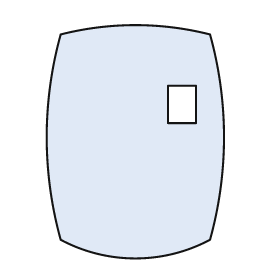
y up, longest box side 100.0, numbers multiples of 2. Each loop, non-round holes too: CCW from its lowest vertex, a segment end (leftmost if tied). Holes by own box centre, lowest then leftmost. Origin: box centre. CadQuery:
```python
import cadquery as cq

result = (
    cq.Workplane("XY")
    .moveTo(-32.0, -42.0)
    .threePointArc((0.0, -50.0), (32.0, -42.0))
    .threePointArc((38.0, 2.0), (32.0, 46.0))
    .threePointArc((0.0, 50.0), (-32.0, 46.0))
    .threePointArc((-38.0, 2.0), (-32.0, -42.0))
    .close()
    .moveTo(14.0, 8.0)
    .lineTo(26.0, 8.0)
    .lineTo(26.0, 24.0)
    .lineTo(14.0, 24.0)
    .close()
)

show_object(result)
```